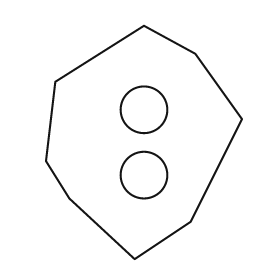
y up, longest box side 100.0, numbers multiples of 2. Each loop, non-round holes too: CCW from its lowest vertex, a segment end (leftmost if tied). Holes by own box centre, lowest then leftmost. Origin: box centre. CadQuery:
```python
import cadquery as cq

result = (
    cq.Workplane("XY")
    .moveTo(-4.0, -50.0)
    .lineTo(20.0, -34.0)
    .lineTo(42.0, 10.0)
    .lineTo(22.0, 38.0)
    .lineTo(0.0, 50.0)
    .lineTo(-38.0, 26.0)
    .lineTo(-42.0, -8.0)
    .lineTo(-32.0, -24.0)
    .close()
    .moveTo(0.0, -14.0)
    .circle(10.0)
    .moveTo(0.0, 14.0)
    .circle(10.0)
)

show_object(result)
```